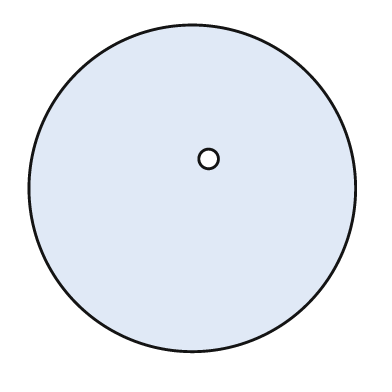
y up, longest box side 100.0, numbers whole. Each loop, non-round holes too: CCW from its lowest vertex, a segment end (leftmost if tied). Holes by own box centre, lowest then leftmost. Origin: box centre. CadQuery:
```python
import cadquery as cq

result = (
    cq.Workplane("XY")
    .moveTo(0.0, 0.0)
    .circle(50.0)
    .moveTo(5.0, 9.0)
    .circle(3.0)
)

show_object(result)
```